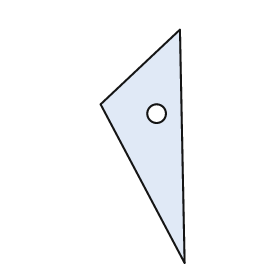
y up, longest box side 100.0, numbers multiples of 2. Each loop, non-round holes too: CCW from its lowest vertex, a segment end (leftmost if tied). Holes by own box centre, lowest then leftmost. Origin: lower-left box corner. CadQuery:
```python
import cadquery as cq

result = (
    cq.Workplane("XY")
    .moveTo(36.0, 0.0)
    .lineTo(34.0, 100.0)
    .lineTo(0.0, 68.0)
    .close()
    .moveTo(24.0, 64.0)
    .circle(4.0)
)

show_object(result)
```